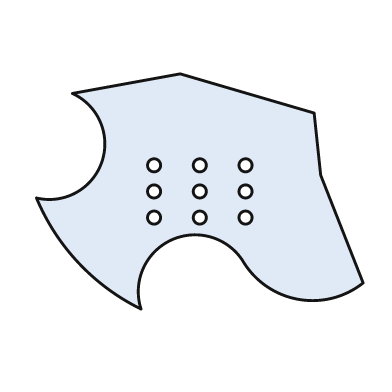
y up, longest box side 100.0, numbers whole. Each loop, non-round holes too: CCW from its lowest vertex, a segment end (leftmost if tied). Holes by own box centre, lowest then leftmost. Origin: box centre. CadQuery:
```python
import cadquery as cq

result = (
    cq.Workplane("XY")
    .moveTo(-18.0, -36.0)
    .threePointArc((-9.0, -15.0), (13.0, -21.0))
    .threePointArc((30.0, -33.0), (50.0, -28.0))
    .lineTo(37.0, 5.0)
    .lineTo(35.0, 24.0)
    .lineTo(-6.0, 36.0)
    .lineTo(-39.0, 30.0)
    .threePointArc((-30.0, 9.0), (-50.0, -2.0))
    .threePointArc((-37.0, -22.0), (-18.0, -36.0))
    .close()
    .moveTo(-14.0, -8.0)
    .circle(2.0)
    .moveTo(0.0, -8.0)
    .circle(2.0)
    .moveTo(14.0, -8.0)
    .circle(2.0)
    .moveTo(-14.0, 0.0)
    .circle(2.0)
    .moveTo(0.0, 0.0)
    .circle(2.0)
    .moveTo(14.0, 0.0)
    .circle(2.0)
    .moveTo(-14.0, 8.0)
    .circle(2.0)
    .moveTo(0.0, 8.0)
    .circle(2.0)
    .moveTo(14.0, 8.0)
    .circle(2.0)
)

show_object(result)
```